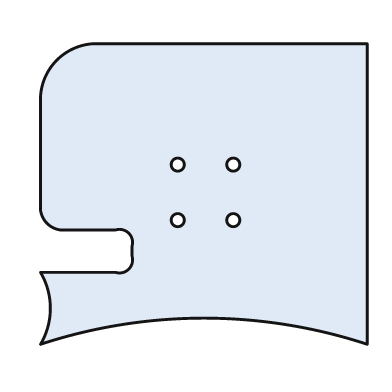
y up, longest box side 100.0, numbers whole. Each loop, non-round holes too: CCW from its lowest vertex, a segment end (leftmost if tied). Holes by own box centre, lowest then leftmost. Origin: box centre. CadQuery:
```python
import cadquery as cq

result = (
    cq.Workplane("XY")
    .moveTo(-50.0, -46.0)
    .threePointArc((0.0, -38.0), (50.0, -46.0))
    .lineTo(50.0, 46.0)
    .lineTo(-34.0, 46.0)
    .threePointArc((-45.0, 41.0), (-50.0, 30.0))
    .lineTo(-50.0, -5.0)
    .threePointArc((-48.0, -9.0), (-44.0, -11.0))
    .lineTo(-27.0, -11.0)
    .threePointArc((-23.0, -12.0), (-22.0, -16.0))
    .lineTo(-22.0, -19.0)
    .threePointArc((-23.0, -23.0), (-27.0, -24.0))
    .lineTo(-50.0, -24.0)
    .threePointArc((-47.0, -35.0), (-50.0, -46.0))
    .close()
    .moveTo(-8.0, -8.0)
    .circle(2.0)
    .moveTo(9.0, -8.0)
    .circle(2.0)
    .moveTo(-8.0, 9.0)
    .circle(2.0)
    .moveTo(9.0, 9.0)
    .circle(2.0)
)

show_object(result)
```